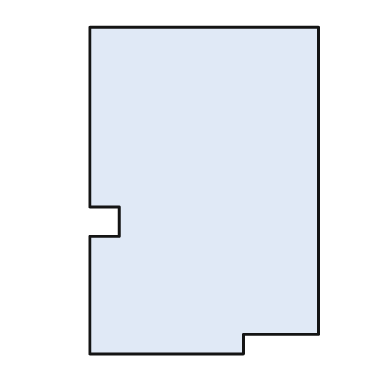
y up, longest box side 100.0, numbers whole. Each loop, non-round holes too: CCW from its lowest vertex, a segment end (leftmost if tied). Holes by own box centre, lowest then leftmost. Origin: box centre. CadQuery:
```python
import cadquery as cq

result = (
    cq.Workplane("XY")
    .moveTo(-35.0, -50.0)
    .lineTo(12.0, -50.0)
    .lineTo(12.0, -44.0)
    .lineTo(35.0, -44.0)
    .lineTo(35.0, 50.0)
    .lineTo(-35.0, 50.0)
    .lineTo(-35.0, -5.0)
    .lineTo(-26.0, -5.0)
    .lineTo(-26.0, -14.0)
    .lineTo(-35.0, -14.0)
    .close()
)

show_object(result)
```